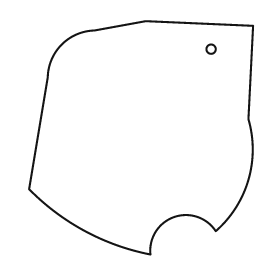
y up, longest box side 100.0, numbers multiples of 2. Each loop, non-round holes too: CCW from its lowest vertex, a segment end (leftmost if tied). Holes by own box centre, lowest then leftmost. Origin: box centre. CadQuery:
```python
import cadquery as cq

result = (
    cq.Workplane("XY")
    .moveTo(4.0, -50.0)
    .threePointArc((14.0, -34.0), (32.0, -40.0))
    .threePointArc((46.0, -18.0), (46.0, 8.0))
    .lineTo(48.0, 48.0)
    .lineTo(2.0, 50.0)
    .lineTo(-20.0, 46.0)
    .threePointArc((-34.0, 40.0), (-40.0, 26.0))
    .lineTo(-48.0, -22.0)
    .threePointArc((-24.0, -40.0), (4.0, -50.0))
    .close()
    .moveTo(30.0, 38.0)
    .circle(2.0)
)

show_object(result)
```